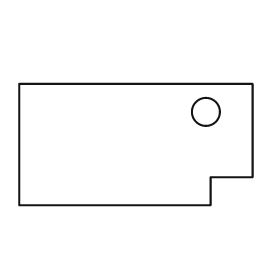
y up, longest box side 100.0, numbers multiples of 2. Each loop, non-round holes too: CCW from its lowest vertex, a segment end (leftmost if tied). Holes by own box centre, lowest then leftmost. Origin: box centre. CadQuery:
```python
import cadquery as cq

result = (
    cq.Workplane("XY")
    .moveTo(-50.0, -26.0)
    .lineTo(32.0, -26.0)
    .lineTo(32.0, -14.0)
    .lineTo(50.0, -14.0)
    .lineTo(50.0, 26.0)
    .lineTo(-50.0, 26.0)
    .close()
    .moveTo(30.0, 14.0)
    .circle(6.0)
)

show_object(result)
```